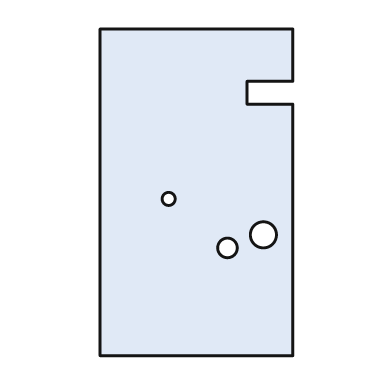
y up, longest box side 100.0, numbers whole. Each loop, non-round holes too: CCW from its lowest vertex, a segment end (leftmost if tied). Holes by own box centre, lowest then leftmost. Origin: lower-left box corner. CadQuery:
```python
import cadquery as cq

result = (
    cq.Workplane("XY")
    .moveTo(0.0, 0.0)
    .lineTo(59.0, 0.0)
    .lineTo(59.0, 77.0)
    .lineTo(45.0, 77.0)
    .lineTo(45.0, 84.0)
    .lineTo(59.0, 84.0)
    .lineTo(59.0, 100.0)
    .lineTo(0.0, 100.0)
    .close()
    .moveTo(39.0, 33.0)
    .circle(3.0)
    .moveTo(50.0, 37.0)
    .circle(4.0)
    .moveTo(21.0, 48.0)
    .circle(2.0)
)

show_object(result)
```